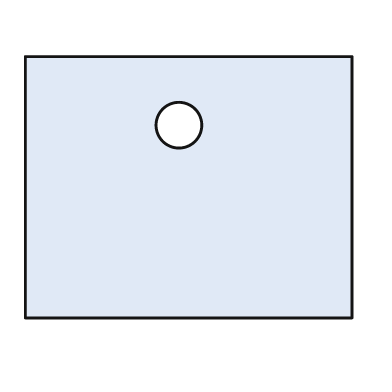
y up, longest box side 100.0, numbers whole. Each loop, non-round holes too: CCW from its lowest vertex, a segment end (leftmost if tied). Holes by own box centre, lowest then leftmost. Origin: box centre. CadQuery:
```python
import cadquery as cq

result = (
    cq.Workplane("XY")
    .moveTo(-50.0, -40.0)
    .lineTo(50.0, -40.0)
    .lineTo(50.0, 40.0)
    .lineTo(-50.0, 40.0)
    .close()
    .moveTo(-3.0, 19.0)
    .circle(7.0)
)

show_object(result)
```